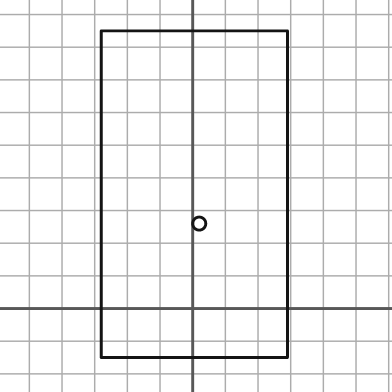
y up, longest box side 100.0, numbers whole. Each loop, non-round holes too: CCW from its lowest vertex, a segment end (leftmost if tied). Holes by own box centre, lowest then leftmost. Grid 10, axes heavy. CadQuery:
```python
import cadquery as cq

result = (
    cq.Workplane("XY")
    .moveTo(-28.0, -15.0)
    .lineTo(29.0, -15.0)
    .lineTo(29.0, 85.0)
    .lineTo(-28.0, 85.0)
    .close()
    .moveTo(2.0, 26.0)
    .circle(2.0)
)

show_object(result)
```